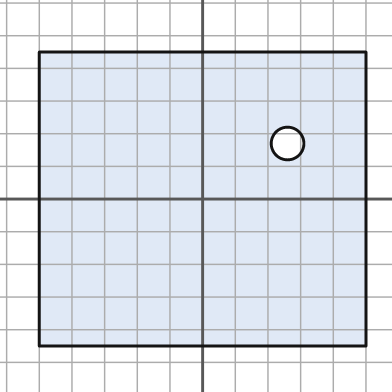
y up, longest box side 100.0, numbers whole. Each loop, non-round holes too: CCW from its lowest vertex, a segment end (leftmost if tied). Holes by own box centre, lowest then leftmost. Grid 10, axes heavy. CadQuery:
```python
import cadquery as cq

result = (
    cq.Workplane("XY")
    .moveTo(-50.0, -45.0)
    .lineTo(50.0, -45.0)
    .lineTo(50.0, 45.0)
    .lineTo(-50.0, 45.0)
    .close()
    .moveTo(26.0, 17.0)
    .circle(5.0)
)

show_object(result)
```